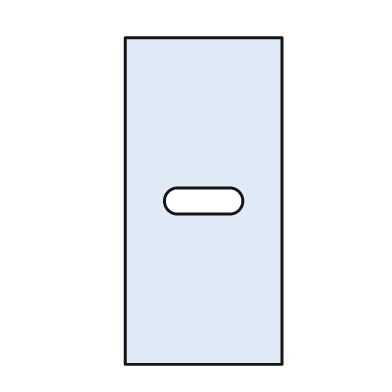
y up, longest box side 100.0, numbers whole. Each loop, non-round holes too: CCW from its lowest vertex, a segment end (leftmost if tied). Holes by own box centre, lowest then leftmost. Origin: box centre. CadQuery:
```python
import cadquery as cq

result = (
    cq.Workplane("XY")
    .moveTo(-24.0, -50.0)
    .lineTo(24.0, -50.0)
    .lineTo(24.0, 50.0)
    .lineTo(-24.0, 50.0)
    .close()
    .moveTo(-8.0, -4.0)
    .lineTo(8.0, -4.0)
    .threePointArc((12.0, 0.0), (8.0, 4.0))
    .lineTo(-8.0, 4.0)
    .threePointArc((-12.0, 0.0), (-8.0, -4.0))
    .close()
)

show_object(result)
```